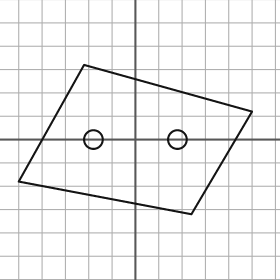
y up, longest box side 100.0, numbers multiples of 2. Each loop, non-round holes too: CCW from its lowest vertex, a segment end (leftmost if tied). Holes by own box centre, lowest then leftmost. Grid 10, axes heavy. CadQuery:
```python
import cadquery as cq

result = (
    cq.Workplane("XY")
    .moveTo(24.0, -32.0)
    .lineTo(50.0, 12.0)
    .lineTo(-22.0, 32.0)
    .lineTo(-50.0, -18.0)
    .close()
    .moveTo(-18.0, 0.0)
    .circle(4.0)
    .moveTo(18.0, 0.0)
    .circle(4.0)
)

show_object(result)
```